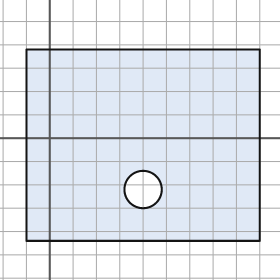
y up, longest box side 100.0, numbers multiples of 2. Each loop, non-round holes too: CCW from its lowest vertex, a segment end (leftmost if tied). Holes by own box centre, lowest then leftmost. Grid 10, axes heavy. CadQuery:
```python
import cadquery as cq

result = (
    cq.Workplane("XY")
    .moveTo(-10.0, -44.0)
    .lineTo(90.0, -44.0)
    .lineTo(90.0, 38.0)
    .lineTo(-10.0, 38.0)
    .close()
    .moveTo(40.0, -22.0)
    .circle(8.0)
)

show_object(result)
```